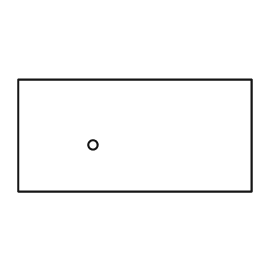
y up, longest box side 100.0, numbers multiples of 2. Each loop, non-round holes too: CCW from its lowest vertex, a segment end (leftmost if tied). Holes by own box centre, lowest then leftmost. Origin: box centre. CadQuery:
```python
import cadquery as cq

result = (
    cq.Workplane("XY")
    .moveTo(-50.0, -24.0)
    .lineTo(50.0, -24.0)
    .lineTo(50.0, 24.0)
    .lineTo(-50.0, 24.0)
    .close()
    .moveTo(-18.0, -4.0)
    .circle(2.0)
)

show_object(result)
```